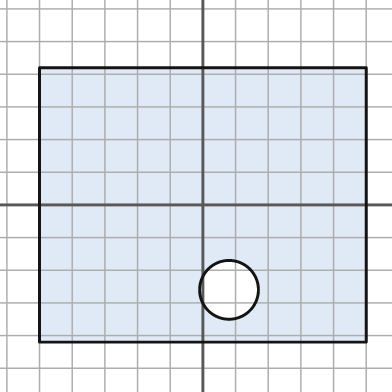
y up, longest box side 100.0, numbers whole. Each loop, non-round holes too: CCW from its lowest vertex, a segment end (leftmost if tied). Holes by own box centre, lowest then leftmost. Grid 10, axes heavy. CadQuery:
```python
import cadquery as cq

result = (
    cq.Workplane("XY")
    .moveTo(-50.0, -42.0)
    .lineTo(50.0, -42.0)
    .lineTo(50.0, 42.0)
    .lineTo(-50.0, 42.0)
    .close()
    .moveTo(8.0, -26.0)
    .circle(9.0)
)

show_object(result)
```